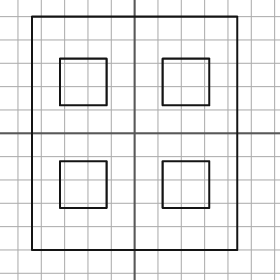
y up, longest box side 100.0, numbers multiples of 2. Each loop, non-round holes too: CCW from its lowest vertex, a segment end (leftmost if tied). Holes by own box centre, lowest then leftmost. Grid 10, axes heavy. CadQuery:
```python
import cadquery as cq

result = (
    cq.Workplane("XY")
    .moveTo(-44.0, -50.0)
    .lineTo(44.0, -50.0)
    .lineTo(44.0, 50.0)
    .lineTo(-44.0, 50.0)
    .close()
    .moveTo(-32.0, -32.0)
    .lineTo(-12.0, -32.0)
    .lineTo(-12.0, -12.0)
    .lineTo(-32.0, -12.0)
    .close()
    .moveTo(12.0, -32.0)
    .lineTo(32.0, -32.0)
    .lineTo(32.0, -12.0)
    .lineTo(12.0, -12.0)
    .close()
    .moveTo(-32.0, 12.0)
    .lineTo(-12.0, 12.0)
    .lineTo(-12.0, 32.0)
    .lineTo(-32.0, 32.0)
    .close()
    .moveTo(12.0, 12.0)
    .lineTo(32.0, 12.0)
    .lineTo(32.0, 32.0)
    .lineTo(12.0, 32.0)
    .close()
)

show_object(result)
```